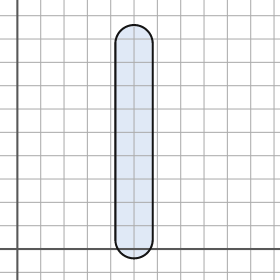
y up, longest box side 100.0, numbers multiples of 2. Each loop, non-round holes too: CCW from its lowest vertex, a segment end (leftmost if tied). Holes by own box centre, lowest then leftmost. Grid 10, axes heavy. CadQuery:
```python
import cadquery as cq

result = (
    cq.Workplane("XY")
    .moveTo(42.0, 4.0)
    .threePointArc((50.0, -4.0), (58.0, 4.0))
    .lineTo(58.0, 88.0)
    .threePointArc((50.0, 96.0), (42.0, 88.0))
    .close()
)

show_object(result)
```